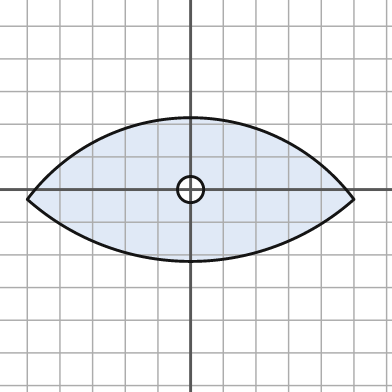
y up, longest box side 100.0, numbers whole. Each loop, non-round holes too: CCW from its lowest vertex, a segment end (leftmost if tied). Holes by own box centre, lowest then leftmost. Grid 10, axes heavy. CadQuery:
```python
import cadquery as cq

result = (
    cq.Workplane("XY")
    .moveTo(-50.0, -3.0)
    .threePointArc((0.0, -22.0), (50.0, -3.0))
    .threePointArc((0.0, 22.0), (-50.0, -3.0))
    .close()
    .moveTo(0.0, 0.0)
    .circle(4.0)
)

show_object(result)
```